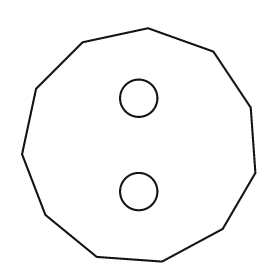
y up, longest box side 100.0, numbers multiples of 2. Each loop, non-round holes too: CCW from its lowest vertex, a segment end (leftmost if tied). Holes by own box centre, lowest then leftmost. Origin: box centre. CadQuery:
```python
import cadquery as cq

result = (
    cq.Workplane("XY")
    .moveTo(10.0, -50.0)
    .lineTo(36.0, -36.0)
    .lineTo(50.0, -12.0)
    .lineTo(48.0, 16.0)
    .lineTo(32.0, 40.0)
    .lineTo(4.0, 50.0)
    .lineTo(-24.0, 44.0)
    .lineTo(-44.0, 24.0)
    .lineTo(-50.0, -4.0)
    .lineTo(-40.0, -30.0)
    .lineTo(-18.0, -48.0)
    .close()
    .moveTo(0.0, -20.0)
    .circle(8.0)
    .moveTo(0.0, 20.0)
    .circle(8.0)
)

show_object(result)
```